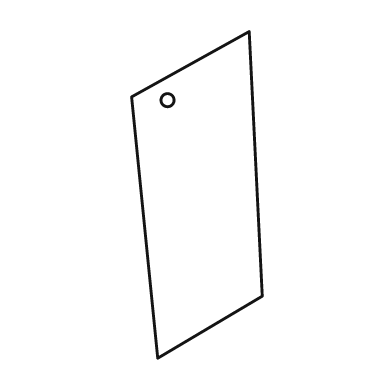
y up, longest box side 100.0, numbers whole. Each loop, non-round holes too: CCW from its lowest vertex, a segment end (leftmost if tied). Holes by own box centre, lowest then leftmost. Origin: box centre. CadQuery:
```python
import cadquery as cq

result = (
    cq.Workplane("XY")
    .moveTo(-12.0, -50.0)
    .lineTo(20.0, -31.0)
    .lineTo(16.0, 50.0)
    .lineTo(-20.0, 30.0)
    .close()
    .moveTo(-9.0, 29.0)
    .circle(2.0)
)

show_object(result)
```